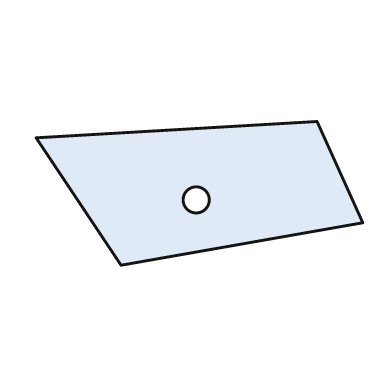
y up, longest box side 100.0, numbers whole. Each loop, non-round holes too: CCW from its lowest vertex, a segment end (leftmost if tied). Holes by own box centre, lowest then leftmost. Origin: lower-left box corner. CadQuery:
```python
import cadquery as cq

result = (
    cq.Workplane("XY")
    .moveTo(26.0, 0.0)
    .lineTo(100.0, 13.0)
    .lineTo(86.0, 44.0)
    .lineTo(0.0, 39.0)
    .close()
    .moveTo(49.0, 20.0)
    .circle(4.0)
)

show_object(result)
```